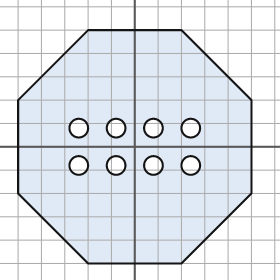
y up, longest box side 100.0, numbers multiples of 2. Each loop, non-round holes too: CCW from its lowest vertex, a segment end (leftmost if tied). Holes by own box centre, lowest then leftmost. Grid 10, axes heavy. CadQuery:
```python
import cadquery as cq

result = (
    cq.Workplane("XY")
    .moveTo(-20.0, -50.0)
    .lineTo(20.0, -50.0)
    .lineTo(50.0, -20.0)
    .lineTo(50.0, 20.0)
    .lineTo(20.0, 50.0)
    .lineTo(-20.0, 50.0)
    .lineTo(-50.0, 20.0)
    .lineTo(-50.0, -20.0)
    .close()
    .moveTo(-24.0, -8.0)
    .circle(4.0)
    .moveTo(-8.0, -8.0)
    .circle(4.0)
    .moveTo(8.0, -8.0)
    .circle(4.0)
    .moveTo(24.0, -8.0)
    .circle(4.0)
    .moveTo(-24.0, 8.0)
    .circle(4.0)
    .moveTo(-8.0, 8.0)
    .circle(4.0)
    .moveTo(8.0, 8.0)
    .circle(4.0)
    .moveTo(24.0, 8.0)
    .circle(4.0)
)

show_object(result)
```